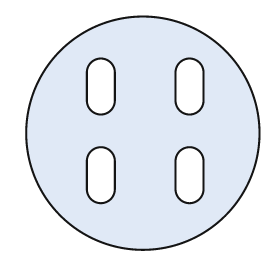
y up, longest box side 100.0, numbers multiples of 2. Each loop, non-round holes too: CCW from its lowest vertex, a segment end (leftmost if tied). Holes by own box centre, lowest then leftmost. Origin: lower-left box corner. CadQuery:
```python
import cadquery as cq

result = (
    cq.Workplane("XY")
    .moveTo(50.0, 50.0)
    .circle(50.0)
    .moveTo(26.0, 26.0)
    .threePointArc((32.0, 20.0), (38.0, 26.0))
    .lineTo(38.0, 38.0)
    .threePointArc((32.0, 44.0), (26.0, 38.0))
    .close()
    .moveTo(64.0, 26.0)
    .threePointArc((70.0, 20.0), (76.0, 26.0))
    .lineTo(76.0, 38.0)
    .threePointArc((70.0, 44.0), (64.0, 38.0))
    .close()
    .moveTo(26.0, 64.0)
    .threePointArc((32.0, 58.0), (38.0, 64.0))
    .lineTo(38.0, 76.0)
    .threePointArc((32.0, 82.0), (26.0, 76.0))
    .close()
    .moveTo(64.0, 64.0)
    .threePointArc((70.0, 58.0), (76.0, 64.0))
    .lineTo(76.0, 76.0)
    .threePointArc((70.0, 82.0), (64.0, 76.0))
    .close()
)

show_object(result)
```